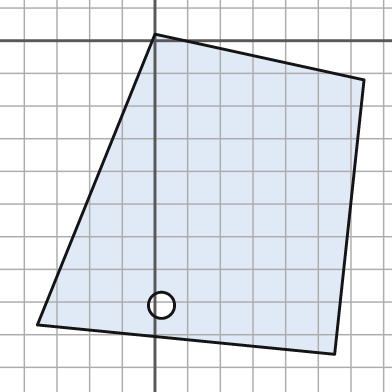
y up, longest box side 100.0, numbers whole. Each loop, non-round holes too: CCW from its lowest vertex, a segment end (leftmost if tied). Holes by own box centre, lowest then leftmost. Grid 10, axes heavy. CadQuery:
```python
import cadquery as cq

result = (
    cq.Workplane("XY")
    .moveTo(55.0, -96.0)
    .lineTo(64.0, -12.0)
    .lineTo(0.0, 2.0)
    .lineTo(-36.0, -87.0)
    .close()
    .moveTo(2.0, -81.0)
    .circle(4.0)
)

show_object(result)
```